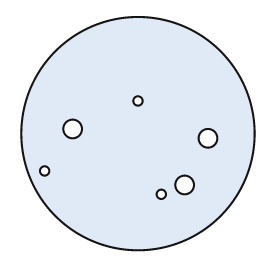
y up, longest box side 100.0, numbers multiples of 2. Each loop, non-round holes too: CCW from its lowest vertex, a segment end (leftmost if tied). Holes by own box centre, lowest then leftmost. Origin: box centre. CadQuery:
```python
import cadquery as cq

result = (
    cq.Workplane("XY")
    .moveTo(0.0, 0.0)
    .circle(50.0)
    .moveTo(10.0, -26.0)
    .circle(2.0)
    .moveTo(20.0, -22.0)
    .circle(4.0)
    .moveTo(-40.0, -16.0)
    .circle(2.0)
    .moveTo(30.0, -2.0)
    .circle(4.0)
    .moveTo(-28.0, 2.0)
    .circle(4.0)
    .moveTo(0.0, 14.0)
    .circle(2.0)
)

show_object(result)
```